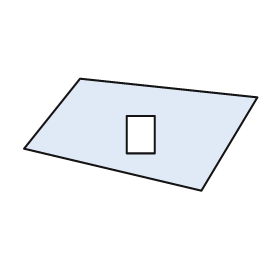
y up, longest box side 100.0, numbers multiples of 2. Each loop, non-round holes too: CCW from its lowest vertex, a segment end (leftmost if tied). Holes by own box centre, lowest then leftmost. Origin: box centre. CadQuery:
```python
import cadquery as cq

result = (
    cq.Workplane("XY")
    .moveTo(26.0, -24.0)
    .lineTo(50.0, 16.0)
    .lineTo(-26.0, 24.0)
    .lineTo(-50.0, -6.0)
    .close()
    .moveTo(-6.0, -8.0)
    .lineTo(6.0, -8.0)
    .lineTo(6.0, 8.0)
    .lineTo(-6.0, 8.0)
    .close()
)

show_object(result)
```